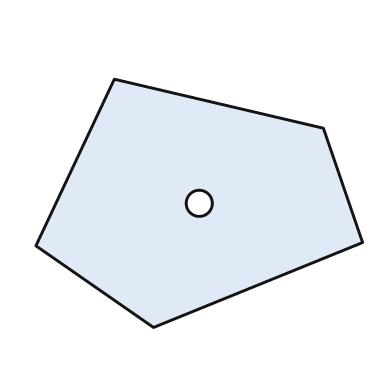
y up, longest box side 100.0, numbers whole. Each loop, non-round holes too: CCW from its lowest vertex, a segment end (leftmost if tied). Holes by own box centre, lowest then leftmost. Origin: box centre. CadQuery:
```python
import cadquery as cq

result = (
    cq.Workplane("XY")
    .moveTo(-14.0, -38.0)
    .lineTo(50.0, -12.0)
    .lineTo(38.0, 23.0)
    .lineTo(-26.0, 38.0)
    .lineTo(-50.0, -13.0)
    .close()
    .moveTo(0.0, 0.0)
    .circle(4.0)
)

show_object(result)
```